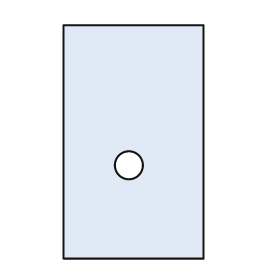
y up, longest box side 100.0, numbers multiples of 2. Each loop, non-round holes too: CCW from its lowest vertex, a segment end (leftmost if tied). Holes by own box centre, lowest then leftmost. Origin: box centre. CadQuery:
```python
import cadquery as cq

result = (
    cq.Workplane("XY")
    .moveTo(-30.0, -50.0)
    .lineTo(30.0, -50.0)
    .lineTo(30.0, 50.0)
    .lineTo(-30.0, 50.0)
    .close()
    .moveTo(-2.0, -10.0)
    .circle(6.0)
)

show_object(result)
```